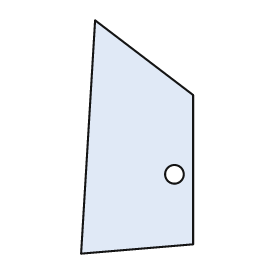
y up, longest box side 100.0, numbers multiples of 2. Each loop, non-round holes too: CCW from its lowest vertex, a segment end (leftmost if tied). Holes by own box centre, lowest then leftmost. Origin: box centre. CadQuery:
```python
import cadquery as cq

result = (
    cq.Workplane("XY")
    .moveTo(-24.0, -50.0)
    .lineTo(24.0, -46.0)
    .lineTo(24.0, 18.0)
    .lineTo(-18.0, 50.0)
    .close()
    .moveTo(16.0, -16.0)
    .circle(4.0)
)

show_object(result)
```